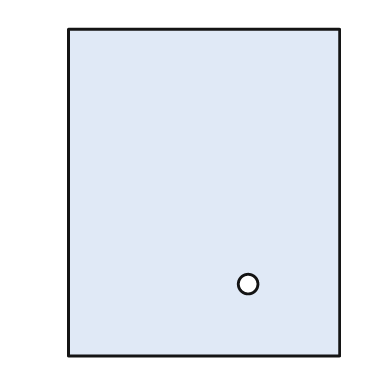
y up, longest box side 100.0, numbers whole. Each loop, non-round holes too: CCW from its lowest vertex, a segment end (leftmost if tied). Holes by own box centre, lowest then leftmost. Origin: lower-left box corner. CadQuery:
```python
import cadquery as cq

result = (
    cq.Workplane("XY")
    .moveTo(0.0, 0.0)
    .lineTo(83.0, 0.0)
    .lineTo(83.0, 100.0)
    .lineTo(0.0, 100.0)
    .close()
    .moveTo(55.0, 22.0)
    .circle(3.0)
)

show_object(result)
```